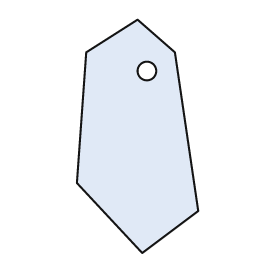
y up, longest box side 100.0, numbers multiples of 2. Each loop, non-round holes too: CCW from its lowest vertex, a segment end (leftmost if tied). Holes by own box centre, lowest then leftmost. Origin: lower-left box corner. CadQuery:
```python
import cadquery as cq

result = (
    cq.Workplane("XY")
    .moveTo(28.0, 0.0)
    .lineTo(52.0, 18.0)
    .lineTo(42.0, 86.0)
    .lineTo(26.0, 100.0)
    .lineTo(4.0, 86.0)
    .lineTo(0.0, 30.0)
    .close()
    .moveTo(30.0, 78.0)
    .circle(4.0)
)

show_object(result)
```